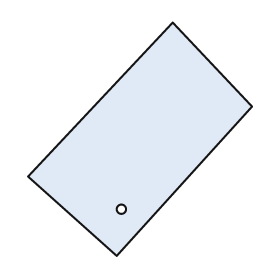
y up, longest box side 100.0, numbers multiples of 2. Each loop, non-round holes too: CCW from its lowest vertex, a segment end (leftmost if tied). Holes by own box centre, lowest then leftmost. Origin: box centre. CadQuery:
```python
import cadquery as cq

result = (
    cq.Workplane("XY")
    .moveTo(-10.0, -50.0)
    .lineTo(48.0, 14.0)
    .lineTo(14.0, 50.0)
    .lineTo(-48.0, -16.0)
    .close()
    .moveTo(-8.0, -30.0)
    .circle(2.0)
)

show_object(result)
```